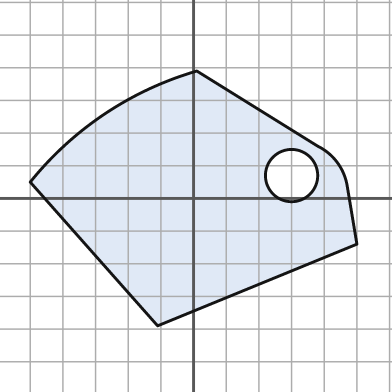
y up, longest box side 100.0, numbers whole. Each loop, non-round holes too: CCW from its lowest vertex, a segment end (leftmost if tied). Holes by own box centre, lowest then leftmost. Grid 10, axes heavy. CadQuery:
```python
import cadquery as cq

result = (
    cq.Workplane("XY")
    .moveTo(-11.0, -39.0)
    .lineTo(50.0, -14.0)
    .lineTo(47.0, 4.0)
    .threePointArc((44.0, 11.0), (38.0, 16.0))
    .lineTo(1.0, 39.0)
    .threePointArc((-27.0, 26.0), (-50.0, 5.0))
    .close()
    .moveTo(30.0, 7.0)
    .circle(8.0)
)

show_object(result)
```